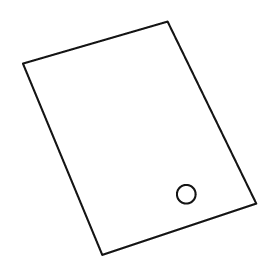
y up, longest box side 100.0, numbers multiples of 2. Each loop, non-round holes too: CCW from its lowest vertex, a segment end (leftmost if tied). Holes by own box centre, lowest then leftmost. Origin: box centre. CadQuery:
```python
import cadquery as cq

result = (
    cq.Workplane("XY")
    .moveTo(-16.0, -50.0)
    .lineTo(50.0, -28.0)
    .lineTo(12.0, 50.0)
    .lineTo(-50.0, 32.0)
    .close()
    .moveTo(20.0, -24.0)
    .circle(4.0)
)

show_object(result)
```